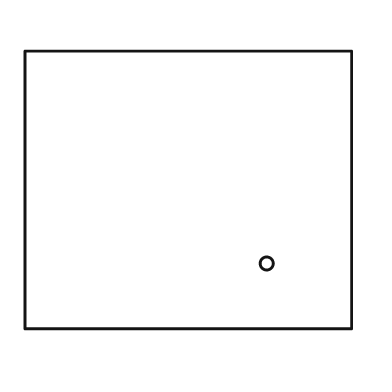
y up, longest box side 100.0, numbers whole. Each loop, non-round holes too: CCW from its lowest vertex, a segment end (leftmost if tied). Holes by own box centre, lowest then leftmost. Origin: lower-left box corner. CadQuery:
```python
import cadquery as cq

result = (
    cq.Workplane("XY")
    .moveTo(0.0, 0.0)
    .lineTo(100.0, 0.0)
    .lineTo(100.0, 85.0)
    .lineTo(0.0, 85.0)
    .close()
    .moveTo(74.0, 20.0)
    .circle(2.0)
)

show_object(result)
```